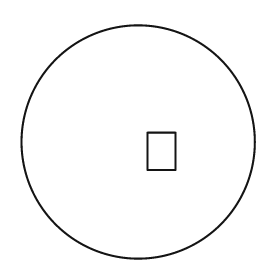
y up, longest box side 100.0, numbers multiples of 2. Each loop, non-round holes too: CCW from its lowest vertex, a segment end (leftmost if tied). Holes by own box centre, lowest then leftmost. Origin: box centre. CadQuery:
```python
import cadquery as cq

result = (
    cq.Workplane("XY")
    .moveTo(0.0, 0.0)
    .circle(50.0)
    .moveTo(4.0, -12.0)
    .lineTo(16.0, -12.0)
    .lineTo(16.0, 4.0)
    .lineTo(4.0, 4.0)
    .close()
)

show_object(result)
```